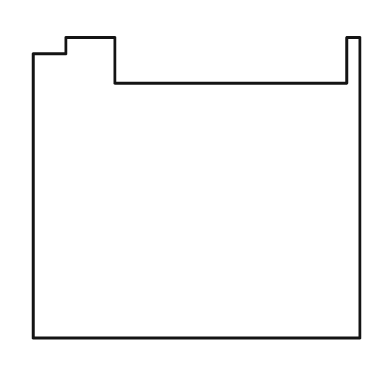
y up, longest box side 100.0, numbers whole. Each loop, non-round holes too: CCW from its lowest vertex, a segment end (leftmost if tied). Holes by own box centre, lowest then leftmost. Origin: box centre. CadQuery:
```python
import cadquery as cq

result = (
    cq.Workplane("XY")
    .moveTo(-50.0, -46.0)
    .lineTo(50.0, -46.0)
    .lineTo(50.0, 46.0)
    .lineTo(46.0, 46.0)
    .lineTo(46.0, 32.0)
    .lineTo(-25.0, 32.0)
    .lineTo(-25.0, 46.0)
    .lineTo(-40.0, 46.0)
    .lineTo(-40.0, 41.0)
    .lineTo(-50.0, 41.0)
    .close()
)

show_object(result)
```